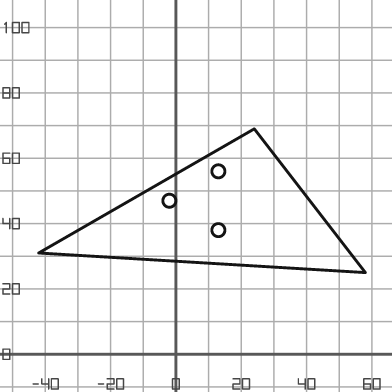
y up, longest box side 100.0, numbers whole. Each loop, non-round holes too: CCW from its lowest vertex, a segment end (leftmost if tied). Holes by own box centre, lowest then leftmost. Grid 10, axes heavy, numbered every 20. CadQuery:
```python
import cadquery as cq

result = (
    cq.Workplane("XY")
    .moveTo(58.0, 25.0)
    .lineTo(24.0, 69.0)
    .lineTo(-42.0, 31.0)
    .close()
    .moveTo(13.0, 38.0)
    .circle(2.0)
    .moveTo(-2.0, 47.0)
    .circle(2.0)
    .moveTo(13.0, 56.0)
    .circle(2.0)
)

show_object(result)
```